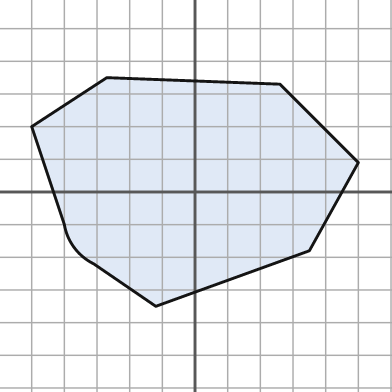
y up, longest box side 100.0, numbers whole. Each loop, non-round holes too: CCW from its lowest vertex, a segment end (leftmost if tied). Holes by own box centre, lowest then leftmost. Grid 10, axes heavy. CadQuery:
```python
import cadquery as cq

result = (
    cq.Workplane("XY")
    .moveTo(-12.0, -35.0)
    .lineTo(35.0, -18.0)
    .lineTo(50.0, 9.0)
    .lineTo(26.0, 33.0)
    .lineTo(-27.0, 35.0)
    .lineTo(-50.0, 20.0)
    .lineTo(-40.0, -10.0)
    .threePointArc((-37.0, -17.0), (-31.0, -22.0))
    .close()
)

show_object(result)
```